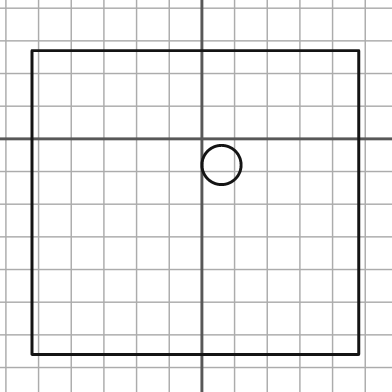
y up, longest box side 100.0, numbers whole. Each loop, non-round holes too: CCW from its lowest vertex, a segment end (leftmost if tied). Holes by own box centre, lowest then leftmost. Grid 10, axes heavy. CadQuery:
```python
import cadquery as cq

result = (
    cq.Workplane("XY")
    .moveTo(-52.0, -66.0)
    .lineTo(48.0, -66.0)
    .lineTo(48.0, 27.0)
    .lineTo(-52.0, 27.0)
    .close()
    .moveTo(6.0, -8.0)
    .circle(6.0)
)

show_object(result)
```